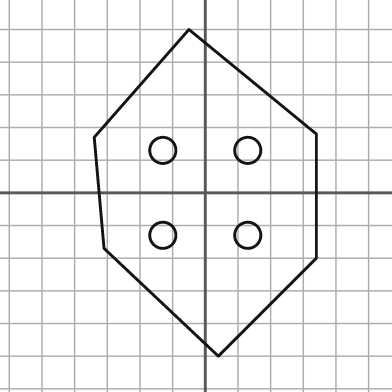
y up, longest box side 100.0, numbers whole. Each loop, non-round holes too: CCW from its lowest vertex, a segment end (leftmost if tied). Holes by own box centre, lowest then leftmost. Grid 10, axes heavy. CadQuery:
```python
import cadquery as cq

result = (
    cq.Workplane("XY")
    .moveTo(4.0, -50.0)
    .lineTo(34.0, -20.0)
    .lineTo(34.0, 18.0)
    .lineTo(-5.0, 50.0)
    .lineTo(-34.0, 17.0)
    .lineTo(-31.0, -17.0)
    .close()
    .moveTo(-13.0, -13.0)
    .circle(4.0)
    .moveTo(13.0, -13.0)
    .circle(4.0)
    .moveTo(-13.0, 13.0)
    .circle(4.0)
    .moveTo(13.0, 13.0)
    .circle(4.0)
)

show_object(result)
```